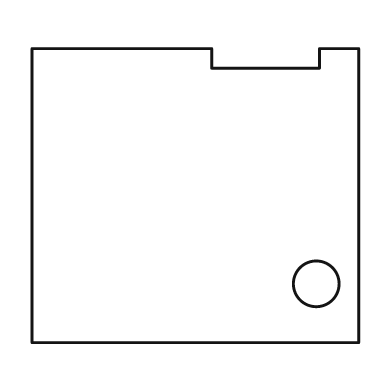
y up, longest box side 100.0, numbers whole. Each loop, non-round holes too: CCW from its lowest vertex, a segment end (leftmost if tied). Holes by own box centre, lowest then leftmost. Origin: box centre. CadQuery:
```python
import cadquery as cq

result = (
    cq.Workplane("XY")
    .moveTo(-50.0, -45.0)
    .lineTo(50.0, -45.0)
    .lineTo(50.0, 45.0)
    .lineTo(38.0, 45.0)
    .lineTo(38.0, 39.0)
    .lineTo(5.0, 39.0)
    .lineTo(5.0, 45.0)
    .lineTo(-50.0, 45.0)
    .close()
    .moveTo(37.0, -27.0)
    .circle(7.0)
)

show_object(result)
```